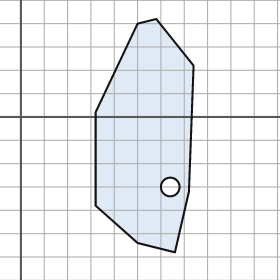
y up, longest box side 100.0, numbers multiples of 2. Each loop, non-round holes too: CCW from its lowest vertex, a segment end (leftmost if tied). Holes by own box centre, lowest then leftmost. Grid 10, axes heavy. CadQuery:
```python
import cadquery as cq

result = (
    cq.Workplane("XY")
    .moveTo(66.0, -58.0)
    .lineTo(72.0, -32.0)
    .lineTo(74.0, 22.0)
    .lineTo(58.0, 42.0)
    .lineTo(50.0, 40.0)
    .lineTo(32.0, 2.0)
    .lineTo(32.0, -38.0)
    .lineTo(50.0, -54.0)
    .close()
    .moveTo(64.0, -30.0)
    .circle(4.0)
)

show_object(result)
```